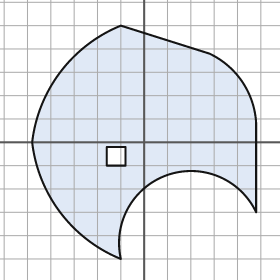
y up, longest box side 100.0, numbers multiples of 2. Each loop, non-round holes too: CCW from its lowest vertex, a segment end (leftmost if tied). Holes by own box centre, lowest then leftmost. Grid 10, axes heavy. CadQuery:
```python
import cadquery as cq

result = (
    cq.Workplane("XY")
    .moveTo(-10.0, -50.0)
    .threePointArc((10.0, -14.0), (48.0, -30.0))
    .lineTo(48.0, 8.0)
    .threePointArc((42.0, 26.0), (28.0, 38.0))
    .lineTo(-10.0, 50.0)
    .threePointArc((-36.0, 30.0), (-48.0, 0.0))
    .threePointArc((-36.0, -30.0), (-10.0, -50.0))
    .close()
    .moveTo(-16.0, -10.0)
    .lineTo(-8.0, -10.0)
    .lineTo(-8.0, -2.0)
    .lineTo(-16.0, -2.0)
    .close()
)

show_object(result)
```